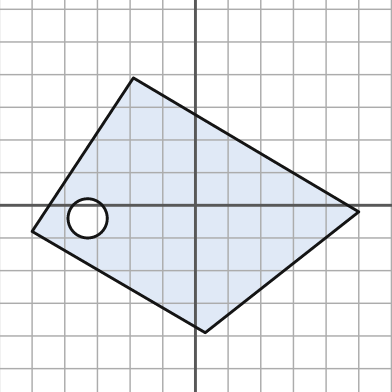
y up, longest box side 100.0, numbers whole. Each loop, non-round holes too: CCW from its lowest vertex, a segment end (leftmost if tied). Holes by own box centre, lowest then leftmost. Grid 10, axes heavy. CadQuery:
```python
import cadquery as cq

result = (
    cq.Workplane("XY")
    .moveTo(3.0, -39.0)
    .lineTo(50.0, -2.0)
    .lineTo(-19.0, 39.0)
    .lineTo(-50.0, -8.0)
    .close()
    .moveTo(-33.0, -4.0)
    .circle(6.0)
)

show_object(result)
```